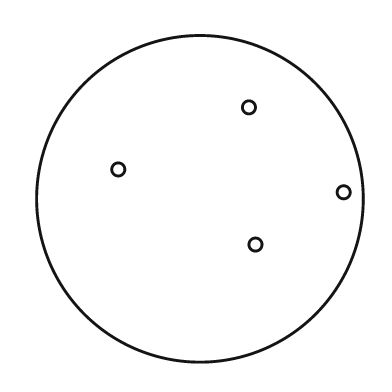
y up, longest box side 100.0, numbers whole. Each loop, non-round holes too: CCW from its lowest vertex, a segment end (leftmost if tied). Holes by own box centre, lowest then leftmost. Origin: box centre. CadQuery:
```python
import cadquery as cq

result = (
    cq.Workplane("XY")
    .moveTo(0.0, 0.0)
    .circle(50.0)
    .moveTo(17.0, -14.0)
    .circle(2.0)
    .moveTo(44.0, 2.0)
    .circle(2.0)
    .moveTo(-25.0, 9.0)
    .circle(2.0)
    .moveTo(15.0, 28.0)
    .circle(2.0)
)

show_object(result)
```